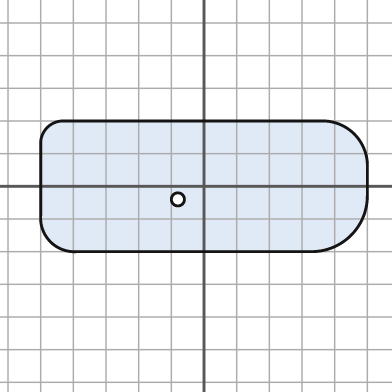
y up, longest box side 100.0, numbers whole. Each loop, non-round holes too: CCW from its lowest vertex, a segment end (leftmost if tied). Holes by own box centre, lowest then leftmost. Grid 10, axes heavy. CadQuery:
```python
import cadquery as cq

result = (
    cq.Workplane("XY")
    .moveTo(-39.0, -20.0)
    .lineTo(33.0, -20.0)
    .threePointArc((45.0, -15.0), (50.0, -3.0))
    .lineTo(50.0, 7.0)
    .threePointArc((46.0, 16.0), (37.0, 20.0))
    .lineTo(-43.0, 20.0)
    .threePointArc((-48.0, 18.0), (-50.0, 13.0))
    .lineTo(-50.0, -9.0)
    .threePointArc((-47.0, -17.0), (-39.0, -20.0))
    .close()
    .moveTo(-8.0, -4.0)
    .circle(2.0)
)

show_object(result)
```